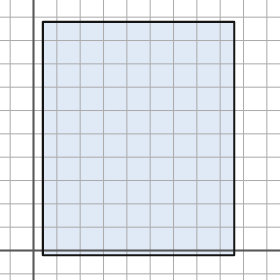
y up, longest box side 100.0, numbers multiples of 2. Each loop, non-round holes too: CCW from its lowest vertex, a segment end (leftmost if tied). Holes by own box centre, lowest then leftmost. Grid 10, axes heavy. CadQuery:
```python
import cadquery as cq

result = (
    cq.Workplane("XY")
    .moveTo(4.0, -2.0)
    .lineTo(86.0, -2.0)
    .lineTo(86.0, 98.0)
    .lineTo(4.0, 98.0)
    .close()
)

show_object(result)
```